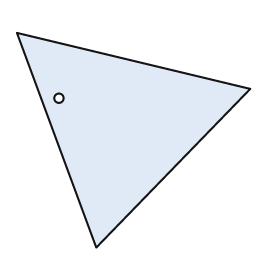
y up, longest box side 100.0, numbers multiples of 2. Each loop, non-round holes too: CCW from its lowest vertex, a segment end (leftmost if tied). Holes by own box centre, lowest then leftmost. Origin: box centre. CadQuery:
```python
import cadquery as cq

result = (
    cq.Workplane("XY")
    .moveTo(-16.0, -46.0)
    .lineTo(50.0, 22.0)
    .lineTo(-50.0, 46.0)
    .close()
    .moveTo(-32.0, 18.0)
    .circle(2.0)
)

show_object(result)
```